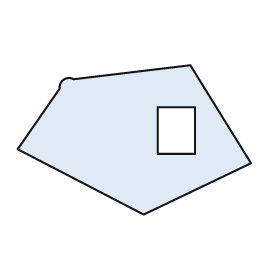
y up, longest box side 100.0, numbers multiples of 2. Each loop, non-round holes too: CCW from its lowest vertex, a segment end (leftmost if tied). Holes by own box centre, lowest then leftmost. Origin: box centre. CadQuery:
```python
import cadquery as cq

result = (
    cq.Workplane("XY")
    .moveTo(4.0, -32.0)
    .lineTo(50.0, -10.0)
    .lineTo(24.0, 32.0)
    .lineTo(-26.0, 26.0)
    .threePointArc((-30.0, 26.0), (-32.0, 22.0))
    .lineTo(-50.0, -4.0)
    .close()
    .moveTo(10.0, -6.0)
    .lineTo(26.0, -6.0)
    .lineTo(26.0, 14.0)
    .lineTo(10.0, 14.0)
    .close()
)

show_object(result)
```